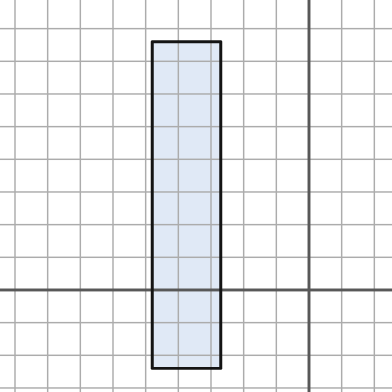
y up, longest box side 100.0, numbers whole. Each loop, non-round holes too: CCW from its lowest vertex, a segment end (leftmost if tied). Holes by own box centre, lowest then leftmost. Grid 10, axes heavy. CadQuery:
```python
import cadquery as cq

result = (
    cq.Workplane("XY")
    .moveTo(-48.0, -24.0)
    .lineTo(-27.0, -24.0)
    .lineTo(-27.0, 76.0)
    .lineTo(-48.0, 76.0)
    .close()
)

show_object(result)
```